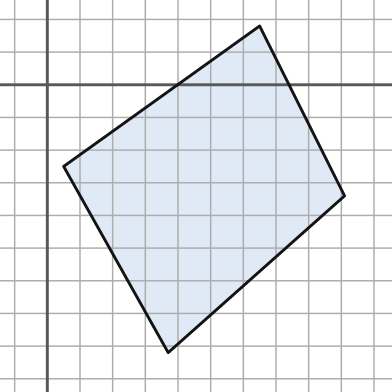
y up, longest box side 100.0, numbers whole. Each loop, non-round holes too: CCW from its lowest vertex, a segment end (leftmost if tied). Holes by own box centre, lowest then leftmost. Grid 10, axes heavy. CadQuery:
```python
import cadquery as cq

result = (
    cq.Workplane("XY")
    .moveTo(37.0, -82.0)
    .lineTo(91.0, -34.0)
    .lineTo(65.0, 18.0)
    .lineTo(5.0, -25.0)
    .close()
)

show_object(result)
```